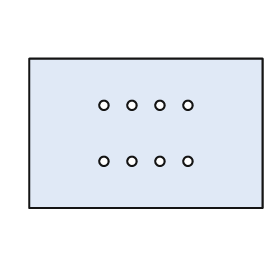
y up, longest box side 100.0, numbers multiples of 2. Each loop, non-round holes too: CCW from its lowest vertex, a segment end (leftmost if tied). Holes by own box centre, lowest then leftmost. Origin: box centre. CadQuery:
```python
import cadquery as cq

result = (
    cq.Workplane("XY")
    .moveTo(-50.0, -32.0)
    .lineTo(50.0, -32.0)
    .lineTo(50.0, 32.0)
    .lineTo(-50.0, 32.0)
    .close()
    .moveTo(-18.0, -12.0)
    .circle(2.0)
    .moveTo(-6.0, -12.0)
    .circle(2.0)
    .moveTo(6.0, -12.0)
    .circle(2.0)
    .moveTo(18.0, -12.0)
    .circle(2.0)
    .moveTo(-18.0, 12.0)
    .circle(2.0)
    .moveTo(-6.0, 12.0)
    .circle(2.0)
    .moveTo(6.0, 12.0)
    .circle(2.0)
    .moveTo(18.0, 12.0)
    .circle(2.0)
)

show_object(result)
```